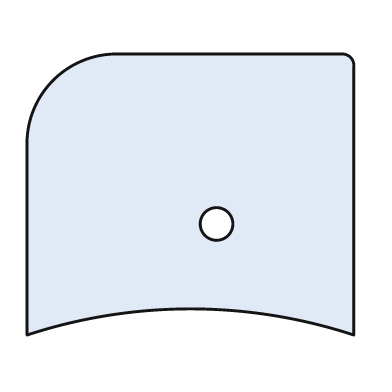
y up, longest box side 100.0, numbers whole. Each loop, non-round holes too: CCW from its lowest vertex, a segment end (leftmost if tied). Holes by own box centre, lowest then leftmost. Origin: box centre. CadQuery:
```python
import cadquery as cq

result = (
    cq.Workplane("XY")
    .moveTo(-50.0, -43.0)
    .threePointArc((0.0, -35.0), (50.0, -43.0))
    .lineTo(50.0, 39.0)
    .threePointArc((49.0, 42.0), (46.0, 43.0))
    .lineTo(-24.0, 43.0)
    .threePointArc((-42.0, 35.0), (-50.0, 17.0))
    .close()
    .moveTo(8.0, -9.0)
    .circle(5.0)
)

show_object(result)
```